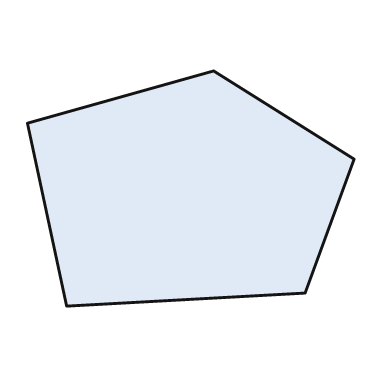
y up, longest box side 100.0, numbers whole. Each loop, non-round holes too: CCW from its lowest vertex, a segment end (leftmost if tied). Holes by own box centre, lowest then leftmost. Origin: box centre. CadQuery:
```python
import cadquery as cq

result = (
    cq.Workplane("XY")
    .moveTo(-38.0, -36.0)
    .lineTo(35.0, -32.0)
    .lineTo(50.0, 9.0)
    .lineTo(7.0, 36.0)
    .lineTo(-50.0, 20.0)
    .close()
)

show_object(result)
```